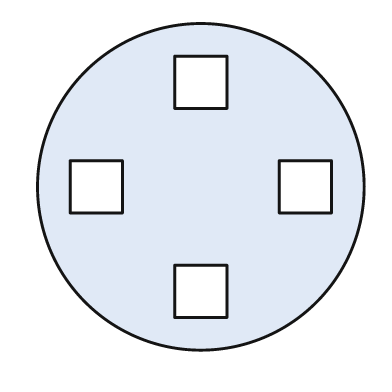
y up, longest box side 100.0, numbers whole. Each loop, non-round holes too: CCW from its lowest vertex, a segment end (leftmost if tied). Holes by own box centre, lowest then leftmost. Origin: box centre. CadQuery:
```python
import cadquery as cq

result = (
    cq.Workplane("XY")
    .moveTo(0.0, 0.0)
    .circle(50.0)
    .moveTo(-8.0, -40.0)
    .lineTo(8.0, -40.0)
    .lineTo(8.0, -24.0)
    .lineTo(-8.0, -24.0)
    .close()
    .moveTo(-40.0, -8.0)
    .lineTo(-24.0, -8.0)
    .lineTo(-24.0, 8.0)
    .lineTo(-40.0, 8.0)
    .close()
    .moveTo(24.0, -8.0)
    .lineTo(40.0, -8.0)
    .lineTo(40.0, 8.0)
    .lineTo(24.0, 8.0)
    .close()
    .moveTo(-8.0, 24.0)
    .lineTo(8.0, 24.0)
    .lineTo(8.0, 40.0)
    .lineTo(-8.0, 40.0)
    .close()
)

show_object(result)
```